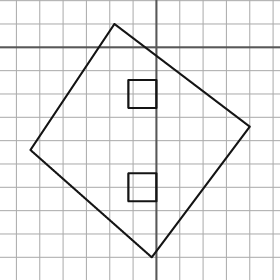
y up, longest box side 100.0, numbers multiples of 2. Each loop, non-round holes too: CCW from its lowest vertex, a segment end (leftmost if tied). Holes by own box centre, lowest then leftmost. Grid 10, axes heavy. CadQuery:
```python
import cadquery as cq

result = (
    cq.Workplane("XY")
    .moveTo(-2.0, -90.0)
    .lineTo(40.0, -34.0)
    .lineTo(-18.0, 10.0)
    .lineTo(-54.0, -44.0)
    .close()
    .moveTo(-12.0, -66.0)
    .lineTo(0.0, -66.0)
    .lineTo(0.0, -54.0)
    .lineTo(-12.0, -54.0)
    .close()
    .moveTo(-12.0, -26.0)
    .lineTo(0.0, -26.0)
    .lineTo(0.0, -14.0)
    .lineTo(-12.0, -14.0)
    .close()
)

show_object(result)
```